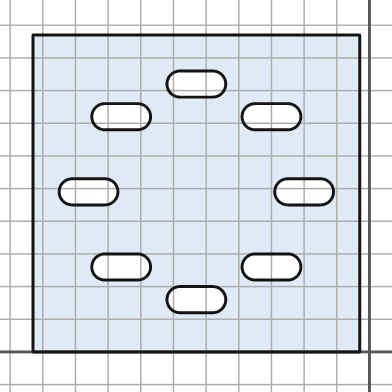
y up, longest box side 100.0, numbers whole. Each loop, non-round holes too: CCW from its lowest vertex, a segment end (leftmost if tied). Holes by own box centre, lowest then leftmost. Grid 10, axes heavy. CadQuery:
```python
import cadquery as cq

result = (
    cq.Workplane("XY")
    .moveTo(-103.0, 0.0)
    .lineTo(-3.0, 0.0)
    .lineTo(-3.0, 97.0)
    .lineTo(-103.0, 97.0)
    .close()
    .moveTo(-58.0, 12.0)
    .lineTo(-48.0, 12.0)
    .threePointArc((-44.0, 16.0), (-48.0, 20.0))
    .lineTo(-58.0, 20.0)
    .threePointArc((-62.0, 16.0), (-58.0, 12.0))
    .close()
    .moveTo(-81.0, 22.0)
    .lineTo(-71.0, 22.0)
    .threePointArc((-67.0, 26.0), (-71.0, 30.0))
    .lineTo(-81.0, 30.0)
    .threePointArc((-85.0, 26.0), (-81.0, 22.0))
    .close()
    .moveTo(-35.0, 22.0)
    .lineTo(-25.0, 22.0)
    .threePointArc((-21.0, 26.0), (-25.0, 30.0))
    .lineTo(-35.0, 30.0)
    .threePointArc((-39.0, 26.0), (-35.0, 22.0))
    .close()
    .moveTo(-91.0, 45.0)
    .lineTo(-81.0, 45.0)
    .threePointArc((-77.0, 49.0), (-81.0, 53.0))
    .lineTo(-91.0, 53.0)
    .threePointArc((-95.0, 49.0), (-91.0, 45.0))
    .close()
    .moveTo(-25.0, 45.0)
    .lineTo(-15.0, 45.0)
    .threePointArc((-11.0, 49.0), (-15.0, 53.0))
    .lineTo(-25.0, 53.0)
    .threePointArc((-29.0, 49.0), (-25.0, 45.0))
    .close()
    .moveTo(-81.0, 68.0)
    .lineTo(-71.0, 68.0)
    .threePointArc((-67.0, 72.0), (-71.0, 76.0))
    .lineTo(-81.0, 76.0)
    .threePointArc((-85.0, 72.0), (-81.0, 68.0))
    .close()
    .moveTo(-35.0, 68.0)
    .lineTo(-25.0, 68.0)
    .threePointArc((-21.0, 72.0), (-25.0, 76.0))
    .lineTo(-35.0, 76.0)
    .threePointArc((-39.0, 72.0), (-35.0, 68.0))
    .close()
    .moveTo(-58.0, 78.0)
    .lineTo(-48.0, 78.0)
    .threePointArc((-44.0, 82.0), (-48.0, 86.0))
    .lineTo(-58.0, 86.0)
    .threePointArc((-62.0, 82.0), (-58.0, 78.0))
    .close()
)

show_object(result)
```